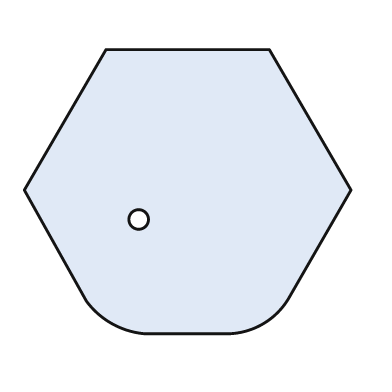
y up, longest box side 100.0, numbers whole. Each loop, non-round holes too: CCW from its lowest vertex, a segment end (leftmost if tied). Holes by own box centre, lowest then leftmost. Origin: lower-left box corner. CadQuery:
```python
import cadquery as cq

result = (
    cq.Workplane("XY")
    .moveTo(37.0, 0.0)
    .lineTo(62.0, 0.0)
    .threePointArc((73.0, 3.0), (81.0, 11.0))
    .lineTo(100.0, 44.0)
    .lineTo(75.0, 87.0)
    .lineTo(25.0, 87.0)
    .lineTo(0.0, 44.0)
    .lineTo(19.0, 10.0)
    .threePointArc((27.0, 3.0), (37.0, 0.0))
    .close()
    .moveTo(35.0, 35.0)
    .circle(3.0)
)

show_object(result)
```